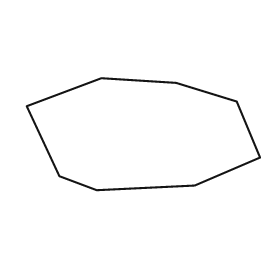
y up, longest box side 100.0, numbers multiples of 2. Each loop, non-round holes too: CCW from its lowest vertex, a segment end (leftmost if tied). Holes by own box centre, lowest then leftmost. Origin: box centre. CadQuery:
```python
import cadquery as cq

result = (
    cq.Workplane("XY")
    .moveTo(-20.0, -24.0)
    .lineTo(22.0, -22.0)
    .lineTo(50.0, -10.0)
    .lineTo(40.0, 14.0)
    .lineTo(14.0, 22.0)
    .lineTo(-18.0, 24.0)
    .lineTo(-50.0, 12.0)
    .lineTo(-36.0, -18.0)
    .close()
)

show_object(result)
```